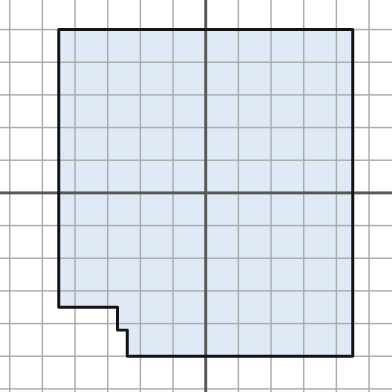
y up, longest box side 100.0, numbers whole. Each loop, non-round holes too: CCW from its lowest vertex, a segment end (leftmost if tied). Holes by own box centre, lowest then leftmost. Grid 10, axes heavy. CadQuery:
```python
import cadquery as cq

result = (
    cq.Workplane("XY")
    .moveTo(-24.0, -50.0)
    .lineTo(45.0, -50.0)
    .lineTo(45.0, 50.0)
    .lineTo(-45.0, 50.0)
    .lineTo(-45.0, -35.0)
    .lineTo(-27.0, -35.0)
    .lineTo(-27.0, -42.0)
    .lineTo(-24.0, -42.0)
    .close()
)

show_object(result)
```